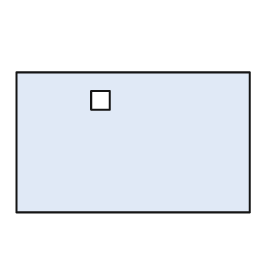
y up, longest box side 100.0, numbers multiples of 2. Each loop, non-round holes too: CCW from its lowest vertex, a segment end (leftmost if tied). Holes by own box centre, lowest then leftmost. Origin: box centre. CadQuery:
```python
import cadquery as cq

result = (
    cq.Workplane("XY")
    .moveTo(-50.0, -30.0)
    .lineTo(50.0, -30.0)
    .lineTo(50.0, 30.0)
    .lineTo(-50.0, 30.0)
    .close()
    .moveTo(-18.0, 14.0)
    .lineTo(-10.0, 14.0)
    .lineTo(-10.0, 22.0)
    .lineTo(-18.0, 22.0)
    .close()
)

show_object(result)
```